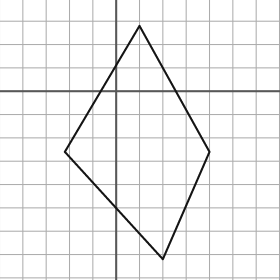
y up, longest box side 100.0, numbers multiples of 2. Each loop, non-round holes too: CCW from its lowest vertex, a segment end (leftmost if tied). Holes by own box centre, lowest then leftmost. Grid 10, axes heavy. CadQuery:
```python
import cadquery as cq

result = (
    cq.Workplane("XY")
    .moveTo(20.0, -72.0)
    .lineTo(40.0, -26.0)
    .lineTo(10.0, 28.0)
    .lineTo(-22.0, -26.0)
    .close()
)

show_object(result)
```